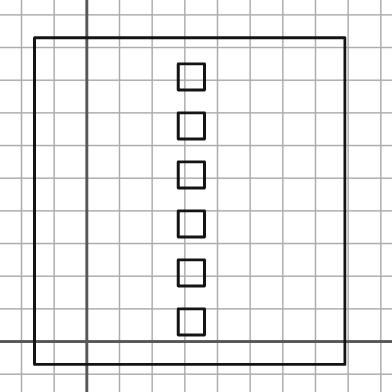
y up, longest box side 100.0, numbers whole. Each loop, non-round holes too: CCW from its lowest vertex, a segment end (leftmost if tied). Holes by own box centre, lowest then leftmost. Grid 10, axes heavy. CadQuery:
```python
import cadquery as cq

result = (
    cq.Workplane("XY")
    .moveTo(-16.0, -7.0)
    .lineTo(79.0, -7.0)
    .lineTo(79.0, 93.0)
    .lineTo(-16.0, 93.0)
    .close()
    .moveTo(28.0, 2.0)
    .lineTo(36.0, 2.0)
    .lineTo(36.0, 10.0)
    .lineTo(28.0, 10.0)
    .close()
    .moveTo(28.0, 17.0)
    .lineTo(36.0, 17.0)
    .lineTo(36.0, 25.0)
    .lineTo(28.0, 25.0)
    .close()
    .moveTo(28.0, 32.0)
    .lineTo(36.0, 32.0)
    .lineTo(36.0, 40.0)
    .lineTo(28.0, 40.0)
    .close()
    .moveTo(28.0, 47.0)
    .lineTo(36.0, 47.0)
    .lineTo(36.0, 55.0)
    .lineTo(28.0, 55.0)
    .close()
    .moveTo(28.0, 62.0)
    .lineTo(36.0, 62.0)
    .lineTo(36.0, 70.0)
    .lineTo(28.0, 70.0)
    .close()
    .moveTo(28.0, 77.0)
    .lineTo(36.0, 77.0)
    .lineTo(36.0, 85.0)
    .lineTo(28.0, 85.0)
    .close()
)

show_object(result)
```